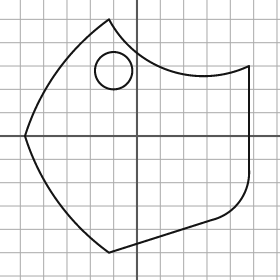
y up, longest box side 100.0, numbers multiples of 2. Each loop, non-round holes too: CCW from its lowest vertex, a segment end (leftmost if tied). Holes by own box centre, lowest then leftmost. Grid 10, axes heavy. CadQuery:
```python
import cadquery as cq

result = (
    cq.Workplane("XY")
    .moveTo(-12.0, -50.0)
    .lineTo(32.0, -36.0)
    .threePointArc((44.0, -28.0), (48.0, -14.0))
    .lineTo(48.0, 30.0)
    .threePointArc((14.0, 28.0), (-12.0, 50.0))
    .threePointArc((-34.0, 28.0), (-48.0, 0.0))
    .threePointArc((-34.0, -28.0), (-12.0, -50.0))
    .close()
    .moveTo(-10.0, 28.0)
    .circle(8.0)
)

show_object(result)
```